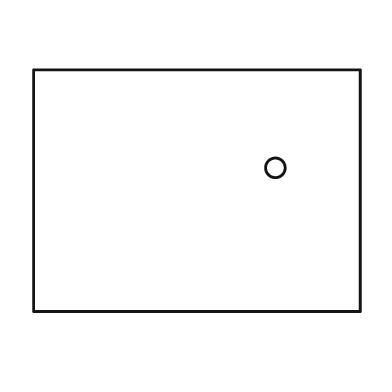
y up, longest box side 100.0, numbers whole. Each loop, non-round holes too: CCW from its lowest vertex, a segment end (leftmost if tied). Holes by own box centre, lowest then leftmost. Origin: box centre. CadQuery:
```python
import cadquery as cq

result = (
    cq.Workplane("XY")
    .moveTo(-50.0, -37.0)
    .lineTo(50.0, -37.0)
    .lineTo(50.0, 37.0)
    .lineTo(-50.0, 37.0)
    .close()
    .moveTo(24.0, 7.0)
    .circle(3.0)
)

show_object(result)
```